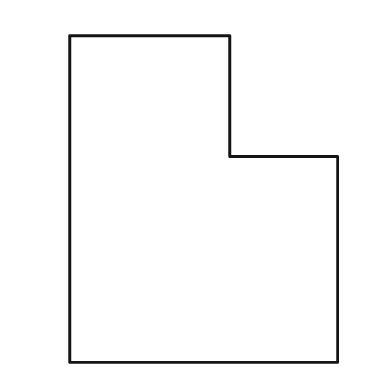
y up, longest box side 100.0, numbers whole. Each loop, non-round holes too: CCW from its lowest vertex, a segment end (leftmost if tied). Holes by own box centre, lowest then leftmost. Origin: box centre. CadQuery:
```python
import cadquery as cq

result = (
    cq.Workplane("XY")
    .moveTo(-41.0, -50.0)
    .lineTo(41.0, -50.0)
    .lineTo(41.0, 13.0)
    .lineTo(8.0, 13.0)
    .lineTo(8.0, 50.0)
    .lineTo(-41.0, 50.0)
    .close()
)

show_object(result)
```